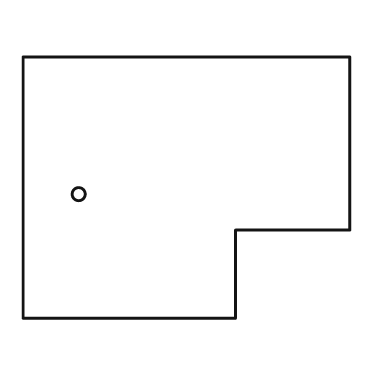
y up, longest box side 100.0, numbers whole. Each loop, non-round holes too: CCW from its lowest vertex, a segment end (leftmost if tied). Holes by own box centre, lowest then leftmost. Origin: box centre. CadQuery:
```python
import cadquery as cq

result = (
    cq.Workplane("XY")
    .moveTo(-50.0, -40.0)
    .lineTo(15.0, -40.0)
    .lineTo(15.0, -13.0)
    .lineTo(50.0, -13.0)
    .lineTo(50.0, 40.0)
    .lineTo(-50.0, 40.0)
    .close()
    .moveTo(-33.0, -2.0)
    .circle(2.0)
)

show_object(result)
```